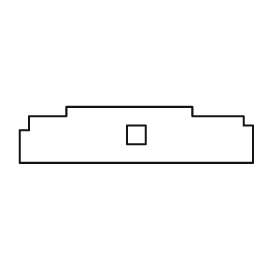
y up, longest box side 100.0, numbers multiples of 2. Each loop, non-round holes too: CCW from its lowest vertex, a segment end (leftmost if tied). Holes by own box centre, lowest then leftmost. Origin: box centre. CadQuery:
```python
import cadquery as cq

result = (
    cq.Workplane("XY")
    .moveTo(-50.0, -12.0)
    .lineTo(50.0, -12.0)
    .lineTo(50.0, 4.0)
    .lineTo(46.0, 4.0)
    .lineTo(46.0, 8.0)
    .lineTo(24.0, 8.0)
    .lineTo(24.0, 12.0)
    .lineTo(-30.0, 12.0)
    .lineTo(-30.0, 8.0)
    .lineTo(-46.0, 8.0)
    .lineTo(-46.0, 2.0)
    .lineTo(-50.0, 2.0)
    .close()
    .moveTo(-4.0, -4.0)
    .lineTo(4.0, -4.0)
    .lineTo(4.0, 4.0)
    .lineTo(-4.0, 4.0)
    .close()
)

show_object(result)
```